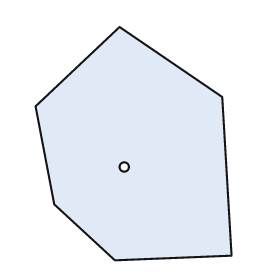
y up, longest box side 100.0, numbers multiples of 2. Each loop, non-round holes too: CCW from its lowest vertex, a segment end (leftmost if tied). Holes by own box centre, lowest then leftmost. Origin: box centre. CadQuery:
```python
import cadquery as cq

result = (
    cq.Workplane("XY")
    .moveTo(-8.0, -50.0)
    .lineTo(42.0, -48.0)
    .lineTo(38.0, 20.0)
    .lineTo(-6.0, 50.0)
    .lineTo(-42.0, 16.0)
    .lineTo(-34.0, -26.0)
    .close()
    .moveTo(-4.0, -10.0)
    .circle(2.0)
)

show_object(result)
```